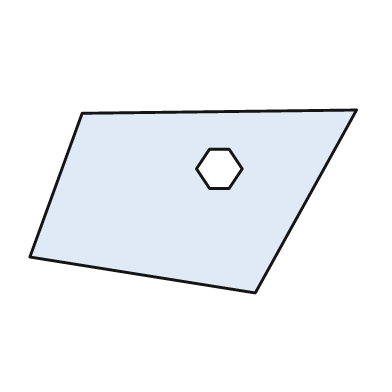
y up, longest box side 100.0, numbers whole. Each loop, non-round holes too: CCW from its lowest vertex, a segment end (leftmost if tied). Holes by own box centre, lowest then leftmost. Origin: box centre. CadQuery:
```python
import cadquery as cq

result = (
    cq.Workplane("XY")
    .moveTo(19.0, -28.0)
    .lineTo(50.0, 28.0)
    .lineTo(-34.0, 27.0)
    .lineTo(-50.0, -17.0)
    .close()
    .moveTo(5.0, 4.0)
    .lineTo(11.0, 4.0)
    .lineTo(15.0, 10.0)
    .lineTo(11.0, 16.0)
    .lineTo(5.0, 16.0)
    .lineTo(1.0, 10.0)
    .close()
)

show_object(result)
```